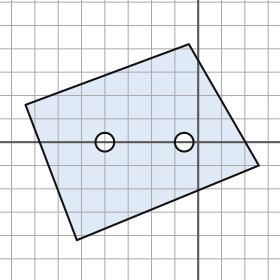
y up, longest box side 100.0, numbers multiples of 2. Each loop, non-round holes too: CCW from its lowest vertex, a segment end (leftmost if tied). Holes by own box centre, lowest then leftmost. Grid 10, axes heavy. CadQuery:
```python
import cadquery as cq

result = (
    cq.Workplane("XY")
    .moveTo(-52.0, -42.0)
    .lineTo(26.0, -10.0)
    .lineTo(-4.0, 42.0)
    .lineTo(-74.0, 16.0)
    .close()
    .moveTo(-40.0, 0.0)
    .circle(4.0)
    .moveTo(-6.0, 0.0)
    .circle(4.0)
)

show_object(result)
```